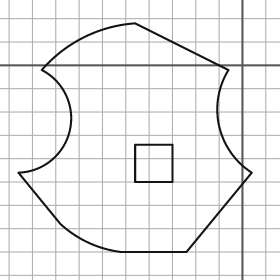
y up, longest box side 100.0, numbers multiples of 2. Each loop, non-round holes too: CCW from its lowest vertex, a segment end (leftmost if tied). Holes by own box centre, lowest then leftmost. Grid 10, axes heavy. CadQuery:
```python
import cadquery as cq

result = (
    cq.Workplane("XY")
    .moveTo(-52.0, -80.0)
    .lineTo(-24.0, -80.0)
    .lineTo(4.0, -46.0)
    .threePointArc((-10.0, -26.0), (-6.0, -2.0))
    .lineTo(-46.0, 18.0)
    .threePointArc((-68.0, 12.0), (-86.0, -2.0))
    .threePointArc((-74.0, -28.0), (-96.0, -46.0))
    .lineTo(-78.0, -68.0)
    .threePointArc((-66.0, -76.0), (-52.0, -80.0))
    .close()
    .moveTo(-46.0, -50.0)
    .lineTo(-30.0, -50.0)
    .lineTo(-30.0, -34.0)
    .lineTo(-46.0, -34.0)
    .close()
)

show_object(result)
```